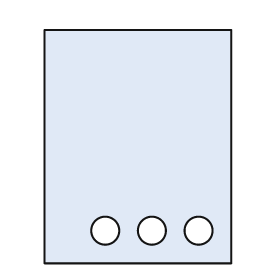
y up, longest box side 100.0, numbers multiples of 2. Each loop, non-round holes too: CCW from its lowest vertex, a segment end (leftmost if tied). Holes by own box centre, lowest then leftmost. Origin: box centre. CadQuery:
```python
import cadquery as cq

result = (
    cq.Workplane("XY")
    .moveTo(-40.0, -50.0)
    .lineTo(40.0, -50.0)
    .lineTo(40.0, 50.0)
    .lineTo(-40.0, 50.0)
    .close()
    .moveTo(-14.0, -36.0)
    .circle(6.0)
    .moveTo(6.0, -36.0)
    .circle(6.0)
    .moveTo(26.0, -36.0)
    .circle(6.0)
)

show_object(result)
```